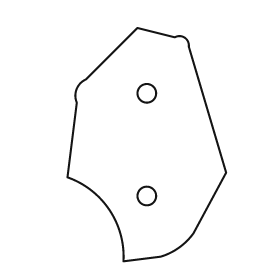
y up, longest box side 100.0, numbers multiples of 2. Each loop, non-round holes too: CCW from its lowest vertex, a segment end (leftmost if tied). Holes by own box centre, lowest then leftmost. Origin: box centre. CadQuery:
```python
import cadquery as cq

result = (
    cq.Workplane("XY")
    .moveTo(-10.0, -50.0)
    .lineTo(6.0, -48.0)
    .threePointArc((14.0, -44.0), (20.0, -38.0))
    .lineTo(34.0, -12.0)
    .lineTo(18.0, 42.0)
    .threePointArc((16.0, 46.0), (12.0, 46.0))
    .lineTo(-4.0, 50.0)
    .lineTo(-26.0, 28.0)
    .threePointArc((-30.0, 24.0), (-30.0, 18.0))
    .lineTo(-34.0, -14.0)
    .threePointArc((-16.0, -28.0), (-10.0, -50.0))
    .close()
    .moveTo(0.0, -22.0)
    .circle(4.0)
    .moveTo(0.0, 22.0)
    .circle(4.0)
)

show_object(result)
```